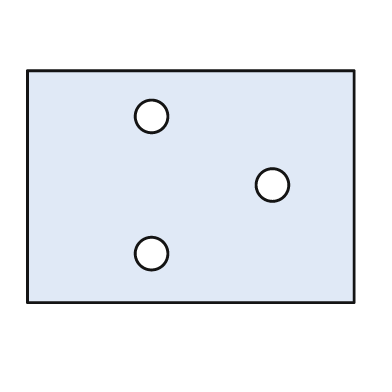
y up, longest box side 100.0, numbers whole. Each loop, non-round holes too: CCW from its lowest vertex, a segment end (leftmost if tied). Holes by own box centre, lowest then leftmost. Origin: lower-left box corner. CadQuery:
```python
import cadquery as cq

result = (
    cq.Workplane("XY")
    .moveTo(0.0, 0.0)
    .lineTo(100.0, 0.0)
    .lineTo(100.0, 71.0)
    .lineTo(0.0, 71.0)
    .close()
    .moveTo(38.0, 15.0)
    .circle(5.0)
    .moveTo(75.0, 36.0)
    .circle(5.0)
    .moveTo(38.0, 57.0)
    .circle(5.0)
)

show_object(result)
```